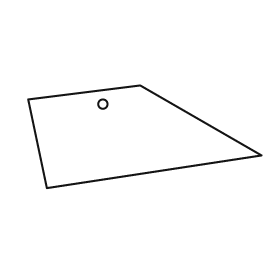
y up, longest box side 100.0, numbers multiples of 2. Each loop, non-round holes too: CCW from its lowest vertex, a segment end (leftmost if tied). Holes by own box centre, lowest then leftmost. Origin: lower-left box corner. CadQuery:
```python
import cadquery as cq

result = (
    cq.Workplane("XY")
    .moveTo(8.0, 0.0)
    .lineTo(100.0, 14.0)
    .lineTo(48.0, 44.0)
    .lineTo(0.0, 38.0)
    .close()
    .moveTo(32.0, 36.0)
    .circle(2.0)
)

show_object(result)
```